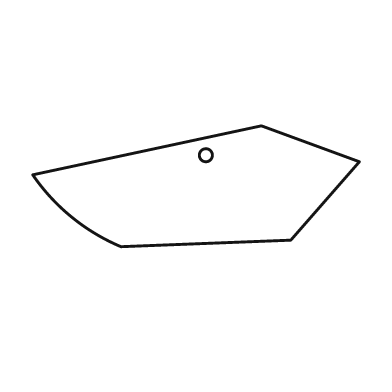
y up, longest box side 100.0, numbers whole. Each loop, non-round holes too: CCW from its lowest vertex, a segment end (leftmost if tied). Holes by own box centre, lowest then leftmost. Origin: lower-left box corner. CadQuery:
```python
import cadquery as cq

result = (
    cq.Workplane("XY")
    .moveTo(27.0, 0.0)
    .lineTo(79.0, 2.0)
    .lineTo(100.0, 26.0)
    .lineTo(70.0, 37.0)
    .lineTo(0.0, 22.0)
    .threePointArc((12.0, 9.0), (27.0, 0.0))
    .close()
    .moveTo(53.0, 28.0)
    .circle(2.0)
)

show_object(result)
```